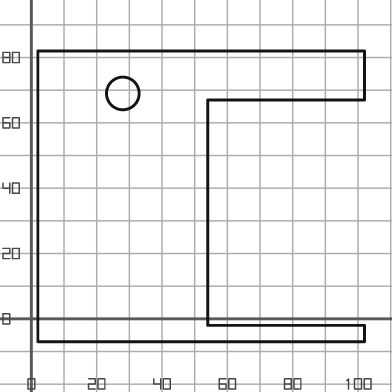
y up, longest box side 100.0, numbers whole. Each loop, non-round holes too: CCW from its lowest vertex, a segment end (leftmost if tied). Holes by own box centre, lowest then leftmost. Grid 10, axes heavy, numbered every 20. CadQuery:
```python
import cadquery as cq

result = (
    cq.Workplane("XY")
    .moveTo(2.0, -7.0)
    .lineTo(102.0, -7.0)
    .lineTo(102.0, -2.0)
    .lineTo(54.0, -2.0)
    .lineTo(54.0, 67.0)
    .lineTo(102.0, 67.0)
    .lineTo(102.0, 82.0)
    .lineTo(2.0, 82.0)
    .close()
    .moveTo(28.0, 69.0)
    .circle(5.0)
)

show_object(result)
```